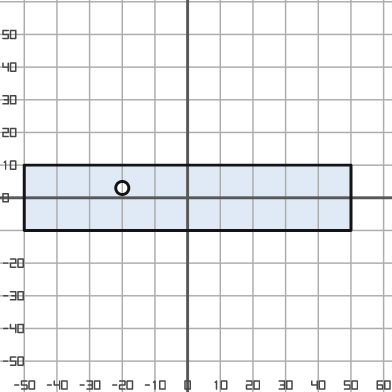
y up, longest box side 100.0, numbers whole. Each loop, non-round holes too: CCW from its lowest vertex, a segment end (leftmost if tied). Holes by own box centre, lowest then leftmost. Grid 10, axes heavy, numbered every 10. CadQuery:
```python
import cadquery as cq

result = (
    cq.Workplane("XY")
    .moveTo(-50.0, -10.0)
    .lineTo(50.0, -10.0)
    .lineTo(50.0, 10.0)
    .lineTo(-50.0, 10.0)
    .close()
    .moveTo(-20.0, 3.0)
    .circle(2.0)
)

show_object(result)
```